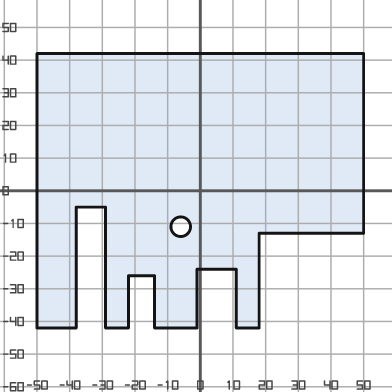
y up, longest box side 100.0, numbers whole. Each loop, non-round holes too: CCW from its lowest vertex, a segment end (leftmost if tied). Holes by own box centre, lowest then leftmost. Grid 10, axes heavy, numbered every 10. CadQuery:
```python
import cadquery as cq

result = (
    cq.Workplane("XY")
    .moveTo(-50.0, -42.0)
    .lineTo(-38.0, -42.0)
    .lineTo(-38.0, -5.0)
    .lineTo(-29.0, -5.0)
    .lineTo(-29.0, -42.0)
    .lineTo(-22.0, -42.0)
    .lineTo(-22.0, -26.0)
    .lineTo(-14.0, -26.0)
    .lineTo(-14.0, -42.0)
    .lineTo(-1.0, -42.0)
    .lineTo(-1.0, -24.0)
    .lineTo(11.0, -24.0)
    .lineTo(11.0, -42.0)
    .lineTo(18.0, -42.0)
    .lineTo(18.0, -13.0)
    .lineTo(50.0, -13.0)
    .lineTo(50.0, 42.0)
    .lineTo(-50.0, 42.0)
    .close()
    .moveTo(-6.0, -11.0)
    .circle(3.0)
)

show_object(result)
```